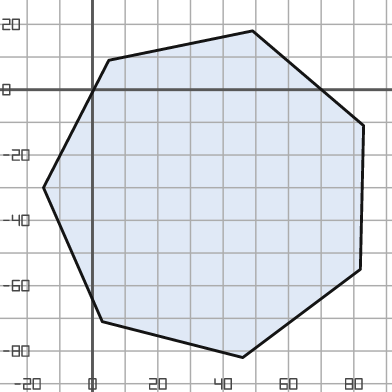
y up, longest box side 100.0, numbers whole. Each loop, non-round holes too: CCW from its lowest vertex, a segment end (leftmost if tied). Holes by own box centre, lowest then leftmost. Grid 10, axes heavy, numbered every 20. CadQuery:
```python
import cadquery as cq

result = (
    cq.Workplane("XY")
    .moveTo(46.0, -82.0)
    .lineTo(82.0, -55.0)
    .lineTo(83.0, -11.0)
    .lineTo(49.0, 18.0)
    .lineTo(5.0, 9.0)
    .lineTo(-15.0, -30.0)
    .lineTo(3.0, -71.0)
    .close()
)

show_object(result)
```